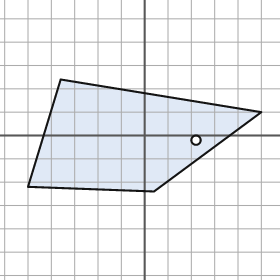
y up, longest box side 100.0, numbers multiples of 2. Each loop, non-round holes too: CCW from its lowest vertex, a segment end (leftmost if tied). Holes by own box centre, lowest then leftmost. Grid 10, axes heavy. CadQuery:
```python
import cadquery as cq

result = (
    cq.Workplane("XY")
    .moveTo(4.0, -24.0)
    .lineTo(50.0, 10.0)
    .lineTo(-36.0, 24.0)
    .lineTo(-50.0, -22.0)
    .close()
    .moveTo(22.0, -2.0)
    .circle(2.0)
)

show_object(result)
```